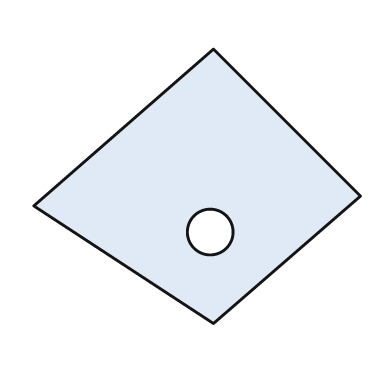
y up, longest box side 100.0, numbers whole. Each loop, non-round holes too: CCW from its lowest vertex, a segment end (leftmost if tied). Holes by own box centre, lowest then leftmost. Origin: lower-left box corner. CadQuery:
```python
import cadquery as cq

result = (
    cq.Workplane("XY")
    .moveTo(55.0, 0.0)
    .lineTo(100.0, 39.0)
    .lineTo(55.0, 84.0)
    .lineTo(0.0, 36.0)
    .close()
    .moveTo(54.0, 28.0)
    .circle(7.0)
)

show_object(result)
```